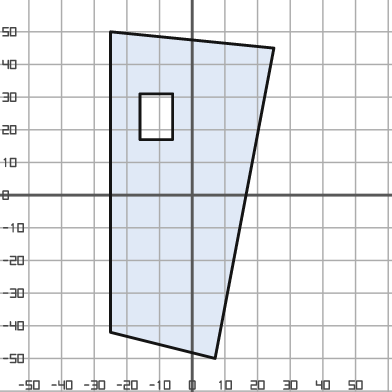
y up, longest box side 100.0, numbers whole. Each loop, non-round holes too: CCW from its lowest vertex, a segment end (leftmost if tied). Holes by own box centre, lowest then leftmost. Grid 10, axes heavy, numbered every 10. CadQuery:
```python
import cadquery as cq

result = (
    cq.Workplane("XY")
    .moveTo(7.0, -50.0)
    .lineTo(25.0, 45.0)
    .lineTo(-25.0, 50.0)
    .lineTo(-25.0, -42.0)
    .close()
    .moveTo(-16.0, 17.0)
    .lineTo(-6.0, 17.0)
    .lineTo(-6.0, 31.0)
    .lineTo(-16.0, 31.0)
    .close()
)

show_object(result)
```